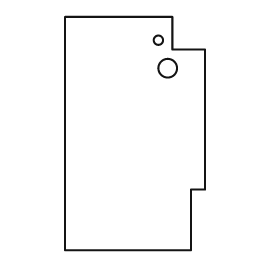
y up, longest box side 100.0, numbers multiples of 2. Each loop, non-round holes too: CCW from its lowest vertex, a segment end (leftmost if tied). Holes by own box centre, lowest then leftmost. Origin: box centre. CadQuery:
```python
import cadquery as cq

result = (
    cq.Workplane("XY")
    .moveTo(-30.0, -50.0)
    .lineTo(24.0, -50.0)
    .lineTo(24.0, -24.0)
    .lineTo(30.0, -24.0)
    .lineTo(30.0, 36.0)
    .lineTo(16.0, 36.0)
    .lineTo(16.0, 50.0)
    .lineTo(-30.0, 50.0)
    .close()
    .moveTo(14.0, 28.0)
    .circle(4.0)
    .moveTo(10.0, 40.0)
    .circle(2.0)
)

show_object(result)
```